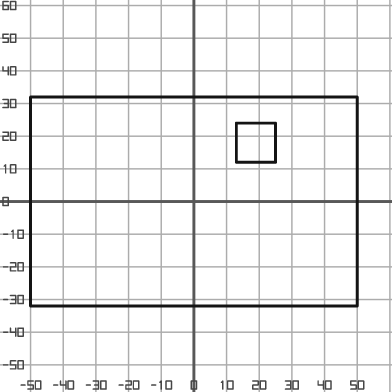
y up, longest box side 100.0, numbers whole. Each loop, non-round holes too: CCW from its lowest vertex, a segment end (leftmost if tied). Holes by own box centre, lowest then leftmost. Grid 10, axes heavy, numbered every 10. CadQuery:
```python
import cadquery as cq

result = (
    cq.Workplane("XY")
    .moveTo(-50.0, -32.0)
    .lineTo(50.0, -32.0)
    .lineTo(50.0, 32.0)
    .lineTo(-50.0, 32.0)
    .close()
    .moveTo(13.0, 12.0)
    .lineTo(25.0, 12.0)
    .lineTo(25.0, 24.0)
    .lineTo(13.0, 24.0)
    .close()
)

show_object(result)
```